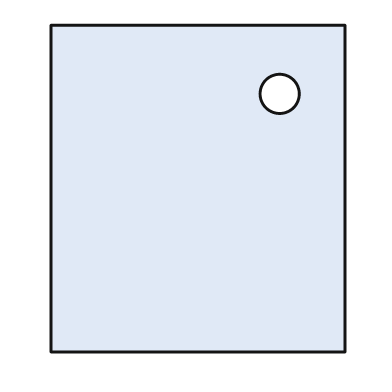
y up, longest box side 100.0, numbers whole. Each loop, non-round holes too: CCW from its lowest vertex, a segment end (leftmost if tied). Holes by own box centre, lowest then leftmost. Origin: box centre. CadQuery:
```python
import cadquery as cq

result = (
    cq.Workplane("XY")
    .moveTo(-45.0, -50.0)
    .lineTo(45.0, -50.0)
    .lineTo(45.0, 50.0)
    .lineTo(-45.0, 50.0)
    .close()
    .moveTo(25.0, 29.0)
    .circle(6.0)
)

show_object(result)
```